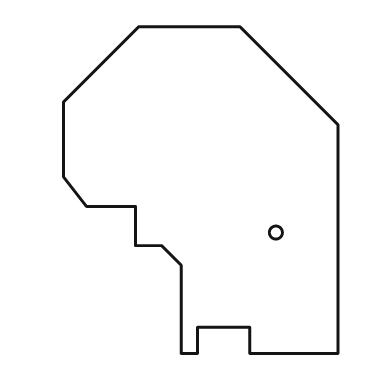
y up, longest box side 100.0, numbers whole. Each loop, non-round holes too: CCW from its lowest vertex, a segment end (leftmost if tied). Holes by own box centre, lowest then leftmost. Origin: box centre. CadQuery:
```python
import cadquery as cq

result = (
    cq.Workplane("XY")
    .moveTo(-6.0, -50.0)
    .lineTo(-1.0, -50.0)
    .lineTo(-1.0, -42.0)
    .lineTo(15.0, -42.0)
    .lineTo(15.0, -50.0)
    .lineTo(42.0, -50.0)
    .lineTo(42.0, 20.0)
    .lineTo(12.0, 50.0)
    .lineTo(-19.0, 50.0)
    .lineTo(-42.0, 27.0)
    .lineTo(-42.0, 4.0)
    .lineTo(-35.0, -5.0)
    .lineTo(-20.0, -5.0)
    .lineTo(-20.0, -17.0)
    .lineTo(-12.0, -17.0)
    .lineTo(-6.0, -23.0)
    .close()
    .moveTo(23.0, -13.0)
    .circle(2.0)
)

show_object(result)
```